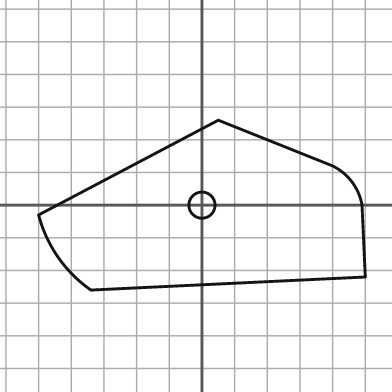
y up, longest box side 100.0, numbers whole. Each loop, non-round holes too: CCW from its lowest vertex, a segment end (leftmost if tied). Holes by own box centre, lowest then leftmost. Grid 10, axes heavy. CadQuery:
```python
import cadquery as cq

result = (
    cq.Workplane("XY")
    .moveTo(-34.0, -26.0)
    .lineTo(50.0, -22.0)
    .lineTo(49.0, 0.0)
    .threePointArc((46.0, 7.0), (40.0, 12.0))
    .lineTo(5.0, 26.0)
    .lineTo(-50.0, -3.0)
    .threePointArc((-44.0, -16.0), (-34.0, -26.0))
    .close()
    .moveTo(0.0, 0.0)
    .circle(4.0)
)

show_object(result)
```